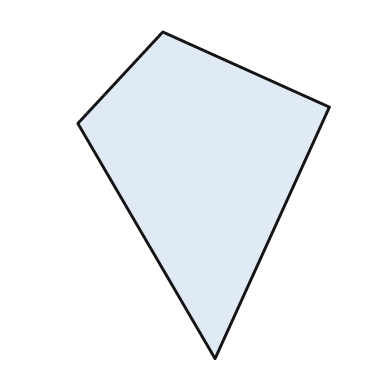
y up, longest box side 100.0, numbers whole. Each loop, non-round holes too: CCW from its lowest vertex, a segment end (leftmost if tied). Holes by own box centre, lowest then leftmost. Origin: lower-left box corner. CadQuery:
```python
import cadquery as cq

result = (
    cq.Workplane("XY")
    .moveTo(42.0, 0.0)
    .lineTo(77.0, 77.0)
    .lineTo(26.0, 100.0)
    .lineTo(0.0, 72.0)
    .close()
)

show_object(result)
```